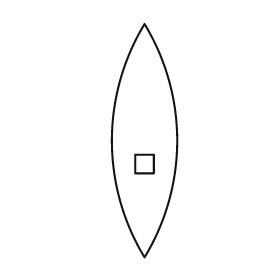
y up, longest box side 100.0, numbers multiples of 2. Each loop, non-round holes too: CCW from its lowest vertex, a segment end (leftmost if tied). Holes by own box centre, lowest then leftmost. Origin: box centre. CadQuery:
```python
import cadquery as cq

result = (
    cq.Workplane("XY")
    .moveTo(0.0, -50.0)
    .threePointArc((14.0, 0.0), (0.0, 50.0))
    .threePointArc((-14.0, 0.0), (0.0, -50.0))
    .close()
    .moveTo(-4.0, -14.0)
    .lineTo(4.0, -14.0)
    .lineTo(4.0, -6.0)
    .lineTo(-4.0, -6.0)
    .close()
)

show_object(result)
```